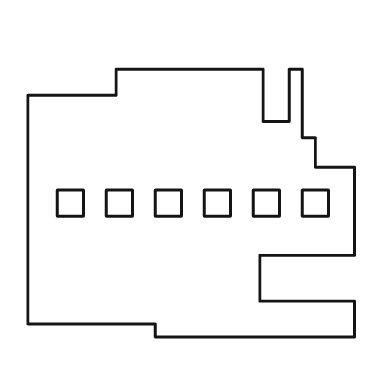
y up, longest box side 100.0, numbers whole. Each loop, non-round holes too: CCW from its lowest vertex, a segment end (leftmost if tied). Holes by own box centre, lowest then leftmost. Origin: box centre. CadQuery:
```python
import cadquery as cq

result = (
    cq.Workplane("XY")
    .moveTo(-11.0, -41.0)
    .lineTo(50.0, -41.0)
    .lineTo(50.0, -30.0)
    .lineTo(21.0, -30.0)
    .lineTo(21.0, -16.0)
    .lineTo(50.0, -16.0)
    .lineTo(50.0, 11.0)
    .lineTo(38.0, 11.0)
    .lineTo(38.0, 20.0)
    .lineTo(34.0, 20.0)
    .lineTo(34.0, 41.0)
    .lineTo(30.0, 41.0)
    .lineTo(30.0, 25.0)
    .lineTo(22.0, 25.0)
    .lineTo(22.0, 41.0)
    .lineTo(-23.0, 41.0)
    .lineTo(-23.0, 33.0)
    .lineTo(-50.0, 33.0)
    .lineTo(-50.0, -37.0)
    .lineTo(-11.0, -37.0)
    .close()
    .moveTo(-41.0, -4.0)
    .lineTo(-33.0, -4.0)
    .lineTo(-33.0, 4.0)
    .lineTo(-41.0, 4.0)
    .close()
    .moveTo(-26.0, -4.0)
    .lineTo(-18.0, -4.0)
    .lineTo(-18.0, 4.0)
    .lineTo(-26.0, 4.0)
    .close()
    .moveTo(-11.0, -4.0)
    .lineTo(-3.0, -4.0)
    .lineTo(-3.0, 4.0)
    .lineTo(-11.0, 4.0)
    .close()
    .moveTo(4.0, -4.0)
    .lineTo(12.0, -4.0)
    .lineTo(12.0, 4.0)
    .lineTo(4.0, 4.0)
    .close()
    .moveTo(19.0, -4.0)
    .lineTo(27.0, -4.0)
    .lineTo(27.0, 4.0)
    .lineTo(19.0, 4.0)
    .close()
    .moveTo(34.0, -4.0)
    .lineTo(42.0, -4.0)
    .lineTo(42.0, 4.0)
    .lineTo(34.0, 4.0)
    .close()
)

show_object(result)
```